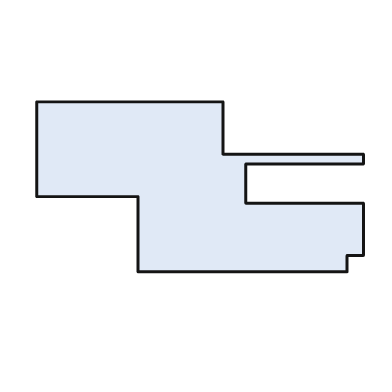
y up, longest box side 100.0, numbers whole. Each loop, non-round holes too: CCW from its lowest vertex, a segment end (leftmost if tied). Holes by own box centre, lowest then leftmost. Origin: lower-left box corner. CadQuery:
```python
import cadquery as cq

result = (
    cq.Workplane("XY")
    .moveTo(31.0, 0.0)
    .lineTo(95.0, 0.0)
    .lineTo(95.0, 5.0)
    .lineTo(100.0, 5.0)
    .lineTo(100.0, 21.0)
    .lineTo(64.0, 21.0)
    .lineTo(64.0, 33.0)
    .lineTo(100.0, 33.0)
    .lineTo(100.0, 36.0)
    .lineTo(57.0, 36.0)
    .lineTo(57.0, 52.0)
    .lineTo(0.0, 52.0)
    .lineTo(0.0, 23.0)
    .lineTo(31.0, 23.0)
    .close()
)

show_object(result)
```